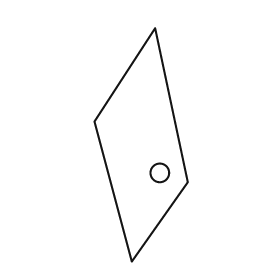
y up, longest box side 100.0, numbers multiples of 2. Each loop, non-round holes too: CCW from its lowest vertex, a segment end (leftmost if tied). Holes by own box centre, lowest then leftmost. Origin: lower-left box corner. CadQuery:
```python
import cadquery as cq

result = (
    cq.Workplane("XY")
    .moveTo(16.0, 0.0)
    .lineTo(40.0, 34.0)
    .lineTo(26.0, 100.0)
    .lineTo(0.0, 60.0)
    .close()
    .moveTo(28.0, 38.0)
    .circle(4.0)
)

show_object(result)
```